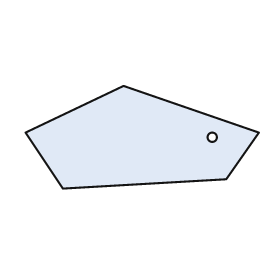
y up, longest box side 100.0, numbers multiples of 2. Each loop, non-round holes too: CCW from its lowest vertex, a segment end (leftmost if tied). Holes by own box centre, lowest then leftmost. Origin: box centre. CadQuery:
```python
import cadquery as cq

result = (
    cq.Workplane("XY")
    .moveTo(-34.0, -22.0)
    .lineTo(36.0, -18.0)
    .lineTo(50.0, 2.0)
    .lineTo(-8.0, 22.0)
    .lineTo(-50.0, 2.0)
    .close()
    .moveTo(30.0, 0.0)
    .circle(2.0)
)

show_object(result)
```